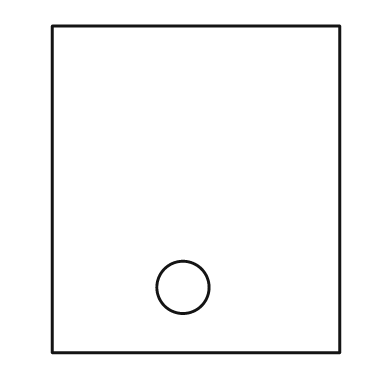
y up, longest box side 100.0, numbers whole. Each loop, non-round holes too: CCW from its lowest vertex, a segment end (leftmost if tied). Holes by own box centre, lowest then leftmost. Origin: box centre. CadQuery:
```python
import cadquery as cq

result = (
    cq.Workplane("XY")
    .moveTo(-44.0, -50.0)
    .lineTo(44.0, -50.0)
    .lineTo(44.0, 50.0)
    .lineTo(-44.0, 50.0)
    .close()
    .moveTo(-4.0, -30.0)
    .circle(8.0)
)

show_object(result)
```